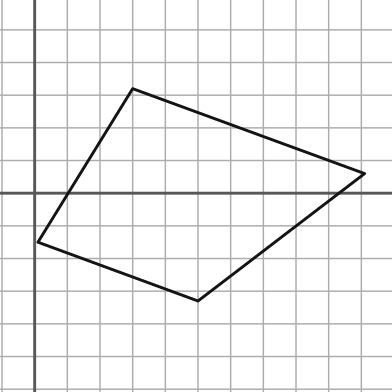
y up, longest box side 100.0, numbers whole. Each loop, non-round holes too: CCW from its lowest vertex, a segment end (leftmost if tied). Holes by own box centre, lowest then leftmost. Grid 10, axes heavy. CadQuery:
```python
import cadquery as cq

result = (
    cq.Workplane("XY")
    .moveTo(50.0, -33.0)
    .lineTo(101.0, 6.0)
    .lineTo(30.0, 32.0)
    .lineTo(1.0, -15.0)
    .close()
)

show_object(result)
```